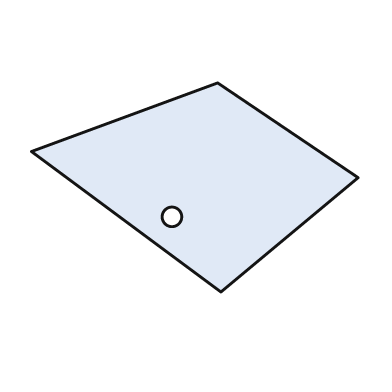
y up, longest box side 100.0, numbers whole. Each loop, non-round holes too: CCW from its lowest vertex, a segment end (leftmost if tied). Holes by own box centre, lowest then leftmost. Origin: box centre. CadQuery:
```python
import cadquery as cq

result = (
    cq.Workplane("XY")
    .moveTo(8.0, -32.0)
    .lineTo(50.0, 3.0)
    .lineTo(7.0, 32.0)
    .lineTo(-50.0, 11.0)
    .close()
    .moveTo(-7.0, -9.0)
    .circle(3.0)
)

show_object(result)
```